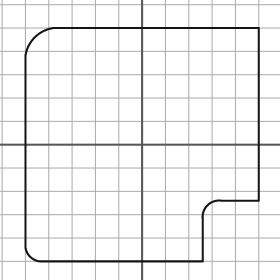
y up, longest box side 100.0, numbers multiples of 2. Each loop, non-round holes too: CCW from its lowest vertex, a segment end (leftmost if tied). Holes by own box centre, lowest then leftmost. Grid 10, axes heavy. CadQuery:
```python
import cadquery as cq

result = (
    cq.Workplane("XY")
    .moveTo(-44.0, -50.0)
    .lineTo(26.0, -50.0)
    .lineTo(26.0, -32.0)
    .threePointArc((28.0, -26.0), (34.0, -24.0))
    .lineTo(50.0, -24.0)
    .lineTo(50.0, 50.0)
    .lineTo(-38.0, 50.0)
    .threePointArc((-46.0, 46.0), (-50.0, 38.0))
    .lineTo(-50.0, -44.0)
    .threePointArc((-48.0, -48.0), (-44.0, -50.0))
    .close()
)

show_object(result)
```